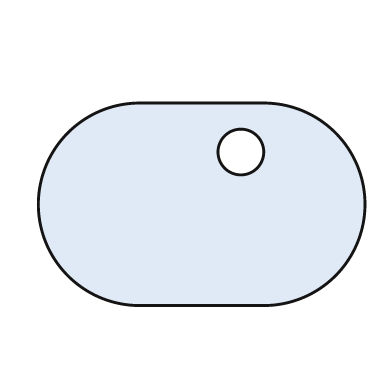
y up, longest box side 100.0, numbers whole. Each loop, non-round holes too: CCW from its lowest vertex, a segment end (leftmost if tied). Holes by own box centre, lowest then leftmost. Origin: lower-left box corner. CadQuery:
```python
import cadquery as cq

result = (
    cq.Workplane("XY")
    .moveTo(31.0, 0.0)
    .lineTo(69.0, 0.0)
    .threePointArc((100.0, 31.0), (69.0, 62.0))
    .lineTo(31.0, 62.0)
    .threePointArc((0.0, 31.0), (31.0, 0.0))
    .close()
    .moveTo(62.0, 47.0)
    .circle(7.0)
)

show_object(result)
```